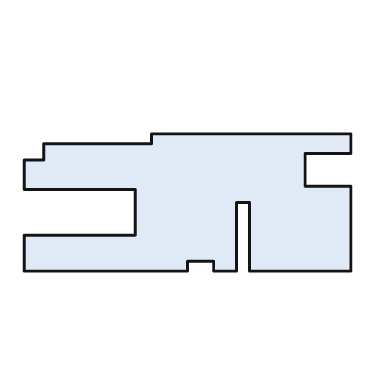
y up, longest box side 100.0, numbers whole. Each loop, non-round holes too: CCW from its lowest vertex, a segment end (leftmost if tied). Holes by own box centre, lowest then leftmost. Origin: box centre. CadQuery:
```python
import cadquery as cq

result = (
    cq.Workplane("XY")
    .moveTo(-50.0, -21.0)
    .lineTo(0.0, -21.0)
    .lineTo(0.0, -18.0)
    .lineTo(8.0, -18.0)
    .lineTo(8.0, -21.0)
    .lineTo(15.0, -21.0)
    .lineTo(15.0, 0.0)
    .lineTo(19.0, 0.0)
    .lineTo(19.0, -21.0)
    .lineTo(50.0, -21.0)
    .lineTo(50.0, 5.0)
    .lineTo(36.0, 5.0)
    .lineTo(36.0, 15.0)
    .lineTo(50.0, 15.0)
    .lineTo(50.0, 21.0)
    .lineTo(-11.0, 21.0)
    .lineTo(-11.0, 18.0)
    .lineTo(-44.0, 18.0)
    .lineTo(-44.0, 13.0)
    .lineTo(-50.0, 13.0)
    .lineTo(-50.0, 4.0)
    .lineTo(-16.0, 4.0)
    .lineTo(-16.0, -10.0)
    .lineTo(-50.0, -10.0)
    .close()
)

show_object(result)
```